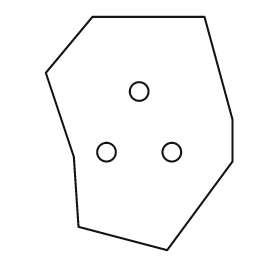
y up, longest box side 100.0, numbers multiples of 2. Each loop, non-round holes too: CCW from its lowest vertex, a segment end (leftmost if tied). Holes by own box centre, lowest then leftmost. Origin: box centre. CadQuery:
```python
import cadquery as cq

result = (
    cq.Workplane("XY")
    .moveTo(12.0, -50.0)
    .lineTo(40.0, -12.0)
    .lineTo(40.0, 6.0)
    .lineTo(28.0, 50.0)
    .lineTo(-20.0, 50.0)
    .lineTo(-40.0, 26.0)
    .lineTo(-28.0, -10.0)
    .lineTo(-26.0, -40.0)
    .close()
    .moveTo(-14.0, -8.0)
    .circle(4.0)
    .moveTo(14.0, -8.0)
    .circle(4.0)
    .moveTo(0.0, 18.0)
    .circle(4.0)
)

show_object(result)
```